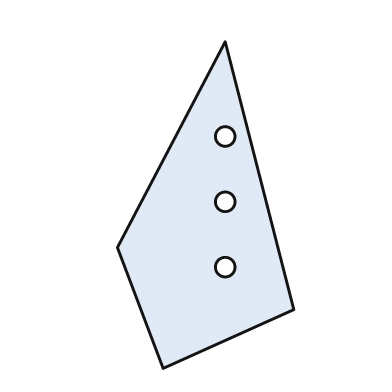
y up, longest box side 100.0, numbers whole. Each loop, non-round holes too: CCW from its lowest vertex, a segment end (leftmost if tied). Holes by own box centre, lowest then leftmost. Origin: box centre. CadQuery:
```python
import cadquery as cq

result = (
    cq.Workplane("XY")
    .moveTo(-13.0, -50.0)
    .lineTo(27.0, -32.0)
    .lineTo(6.0, 50.0)
    .lineTo(-27.0, -13.0)
    .close()
    .moveTo(6.0, -19.0)
    .circle(3.0)
    .moveTo(6.0, 1.0)
    .circle(3.0)
    .moveTo(6.0, 21.0)
    .circle(3.0)
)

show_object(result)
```